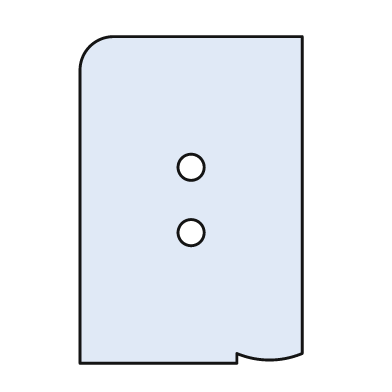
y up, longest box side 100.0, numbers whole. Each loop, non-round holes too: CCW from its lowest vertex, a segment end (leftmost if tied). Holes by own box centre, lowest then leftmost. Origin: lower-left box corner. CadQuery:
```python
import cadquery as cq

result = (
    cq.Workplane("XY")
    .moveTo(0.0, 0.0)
    .lineTo(48.0, 0.0)
    .lineTo(48.0, 3.0)
    .threePointArc((58.0, 1.0), (68.0, 3.0))
    .lineTo(68.0, 100.0)
    .lineTo(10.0, 100.0)
    .threePointArc((3.0, 97.0), (0.0, 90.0))
    .close()
    .moveTo(34.0, 40.0)
    .circle(4.0)
    .moveTo(34.0, 60.0)
    .circle(4.0)
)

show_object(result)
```